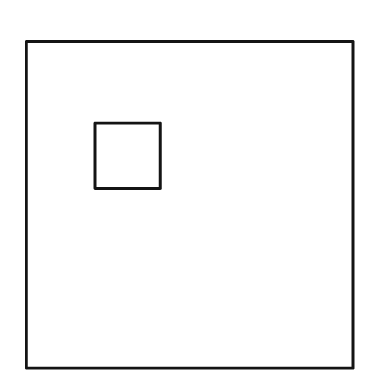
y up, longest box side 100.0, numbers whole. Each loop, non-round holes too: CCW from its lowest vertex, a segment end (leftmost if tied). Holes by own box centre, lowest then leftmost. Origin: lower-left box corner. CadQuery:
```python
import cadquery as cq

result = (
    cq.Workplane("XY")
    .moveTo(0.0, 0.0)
    .lineTo(100.0, 0.0)
    .lineTo(100.0, 100.0)
    .lineTo(0.0, 100.0)
    .close()
    .moveTo(21.0, 55.0)
    .lineTo(41.0, 55.0)
    .lineTo(41.0, 75.0)
    .lineTo(21.0, 75.0)
    .close()
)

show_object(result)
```